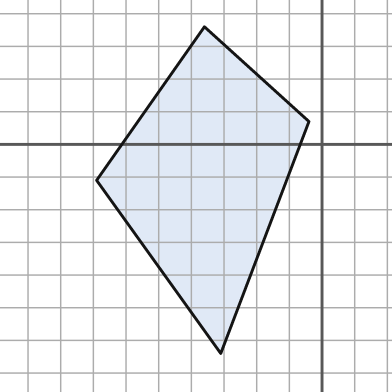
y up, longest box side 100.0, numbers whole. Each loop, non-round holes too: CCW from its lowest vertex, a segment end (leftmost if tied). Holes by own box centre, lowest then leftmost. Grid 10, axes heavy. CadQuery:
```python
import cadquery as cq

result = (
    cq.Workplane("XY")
    .moveTo(-31.0, -64.0)
    .lineTo(-4.0, 7.0)
    .lineTo(-36.0, 36.0)
    .lineTo(-69.0, -11.0)
    .close()
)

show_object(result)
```